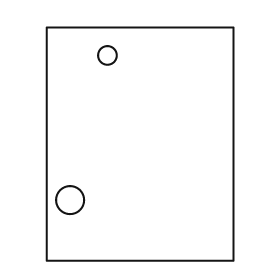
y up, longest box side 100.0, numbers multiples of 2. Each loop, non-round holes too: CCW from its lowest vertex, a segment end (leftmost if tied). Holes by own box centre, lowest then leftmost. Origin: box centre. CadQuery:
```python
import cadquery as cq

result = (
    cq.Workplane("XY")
    .moveTo(-40.0, -50.0)
    .lineTo(40.0, -50.0)
    .lineTo(40.0, 50.0)
    .lineTo(-40.0, 50.0)
    .close()
    .moveTo(-30.0, -24.0)
    .circle(6.0)
    .moveTo(-14.0, 38.0)
    .circle(4.0)
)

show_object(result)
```